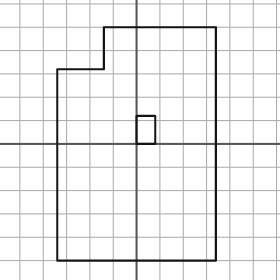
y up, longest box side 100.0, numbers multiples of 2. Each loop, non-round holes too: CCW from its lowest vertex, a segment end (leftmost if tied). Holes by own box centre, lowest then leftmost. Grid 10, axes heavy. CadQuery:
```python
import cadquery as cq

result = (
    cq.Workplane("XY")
    .moveTo(-34.0, -50.0)
    .lineTo(34.0, -50.0)
    .lineTo(34.0, 50.0)
    .lineTo(-14.0, 50.0)
    .lineTo(-14.0, 32.0)
    .lineTo(-34.0, 32.0)
    .close()
    .moveTo(0.0, 0.0)
    .lineTo(8.0, 0.0)
    .lineTo(8.0, 12.0)
    .lineTo(0.0, 12.0)
    .close()
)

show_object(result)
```